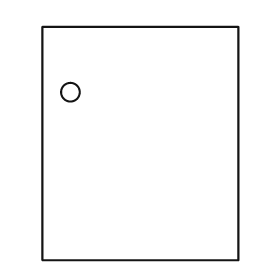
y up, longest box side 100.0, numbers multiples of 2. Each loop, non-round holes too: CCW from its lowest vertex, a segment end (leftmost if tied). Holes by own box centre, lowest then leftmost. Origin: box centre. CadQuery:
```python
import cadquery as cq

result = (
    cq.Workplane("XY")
    .moveTo(-42.0, -50.0)
    .lineTo(42.0, -50.0)
    .lineTo(42.0, 50.0)
    .lineTo(-42.0, 50.0)
    .close()
    .moveTo(-30.0, 22.0)
    .circle(4.0)
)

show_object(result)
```